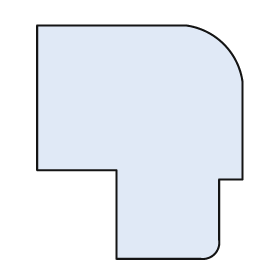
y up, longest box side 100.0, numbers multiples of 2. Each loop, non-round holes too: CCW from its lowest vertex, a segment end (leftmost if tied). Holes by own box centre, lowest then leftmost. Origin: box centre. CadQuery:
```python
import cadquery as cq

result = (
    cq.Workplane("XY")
    .moveTo(-10.0, -50.0)
    .lineTo(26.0, -50.0)
    .threePointArc((32.0, -48.0), (34.0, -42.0))
    .lineTo(34.0, -16.0)
    .lineTo(44.0, -16.0)
    .lineTo(44.0, 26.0)
    .threePointArc((36.0, 42.0), (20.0, 50.0))
    .lineTo(-44.0, 50.0)
    .lineTo(-44.0, -12.0)
    .lineTo(-10.0, -12.0)
    .close()
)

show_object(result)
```